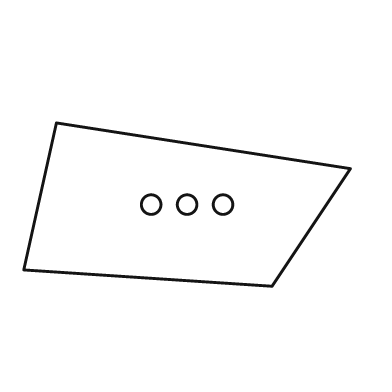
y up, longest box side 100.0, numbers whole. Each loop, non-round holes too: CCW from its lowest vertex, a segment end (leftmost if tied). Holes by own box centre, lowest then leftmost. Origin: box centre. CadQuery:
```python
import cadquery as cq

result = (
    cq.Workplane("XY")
    .moveTo(26.0, -25.0)
    .lineTo(50.0, 11.0)
    .lineTo(-40.0, 25.0)
    .lineTo(-50.0, -20.0)
    .close()
    .moveTo(-11.0, 0.0)
    .circle(3.0)
    .moveTo(0.0, 0.0)
    .circle(3.0)
    .moveTo(11.0, 0.0)
    .circle(3.0)
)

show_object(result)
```